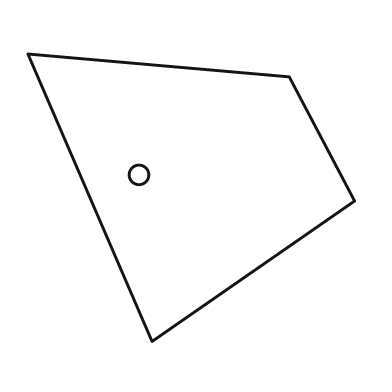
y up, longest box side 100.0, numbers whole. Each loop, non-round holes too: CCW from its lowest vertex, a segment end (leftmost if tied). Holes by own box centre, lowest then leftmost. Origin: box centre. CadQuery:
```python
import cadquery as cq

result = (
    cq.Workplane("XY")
    .moveTo(-12.0, -44.0)
    .lineTo(50.0, -1.0)
    .lineTo(30.0, 37.0)
    .lineTo(-50.0, 44.0)
    .close()
    .moveTo(-16.0, 7.0)
    .circle(3.0)
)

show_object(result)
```